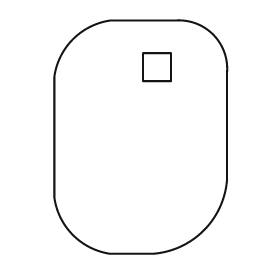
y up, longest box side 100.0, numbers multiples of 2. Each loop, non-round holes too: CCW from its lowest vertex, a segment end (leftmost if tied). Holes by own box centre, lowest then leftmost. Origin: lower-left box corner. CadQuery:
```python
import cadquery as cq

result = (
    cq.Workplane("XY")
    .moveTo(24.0, 0.0)
    .lineTo(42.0, 0.0)
    .threePointArc((64.0, 10.0), (74.0, 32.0))
    .lineTo(74.0, 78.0)
    .threePointArc((68.0, 94.0), (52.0, 100.0))
    .lineTo(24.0, 100.0)
    .threePointArc((8.0, 92.0), (0.0, 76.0))
    .lineTo(0.0, 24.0)
    .threePointArc((8.0, 8.0), (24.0, 0.0))
    .close()
    .moveTo(38.0, 74.0)
    .lineTo(50.0, 74.0)
    .lineTo(50.0, 86.0)
    .lineTo(38.0, 86.0)
    .close()
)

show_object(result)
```